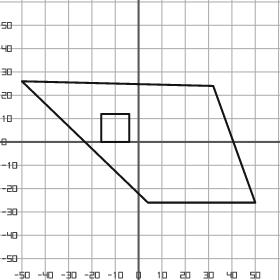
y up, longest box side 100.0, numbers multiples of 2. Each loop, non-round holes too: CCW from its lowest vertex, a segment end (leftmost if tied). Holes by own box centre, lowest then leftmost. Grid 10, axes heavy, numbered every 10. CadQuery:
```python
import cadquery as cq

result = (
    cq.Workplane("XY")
    .moveTo(4.0, -26.0)
    .lineTo(50.0, -26.0)
    .lineTo(32.0, 24.0)
    .lineTo(-50.0, 26.0)
    .close()
    .moveTo(-16.0, 0.0)
    .lineTo(-4.0, 0.0)
    .lineTo(-4.0, 12.0)
    .lineTo(-16.0, 12.0)
    .close()
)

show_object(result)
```